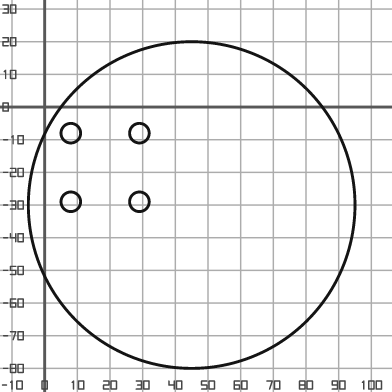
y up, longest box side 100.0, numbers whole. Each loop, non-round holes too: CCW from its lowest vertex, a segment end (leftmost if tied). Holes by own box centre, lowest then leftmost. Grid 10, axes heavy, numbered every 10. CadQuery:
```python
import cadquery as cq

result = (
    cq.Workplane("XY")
    .moveTo(45.0, -30.0)
    .circle(50.0)
    .moveTo(8.0, -29.0)
    .circle(3.0)
    .moveTo(29.0, -29.0)
    .circle(3.0)
    .moveTo(8.0, -8.0)
    .circle(3.0)
    .moveTo(29.0, -8.0)
    .circle(3.0)
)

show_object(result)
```